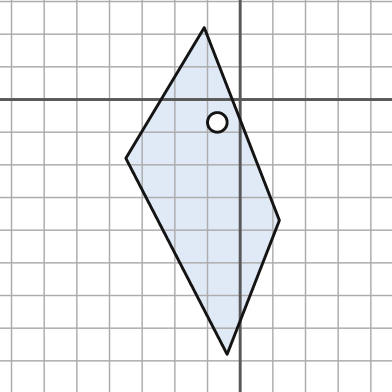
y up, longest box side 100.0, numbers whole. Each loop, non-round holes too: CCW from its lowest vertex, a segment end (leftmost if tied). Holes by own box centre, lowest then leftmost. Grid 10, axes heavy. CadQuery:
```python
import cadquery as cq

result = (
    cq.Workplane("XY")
    .moveTo(-4.0, -78.0)
    .lineTo(12.0, -37.0)
    .lineTo(-11.0, 22.0)
    .lineTo(-35.0, -18.0)
    .close()
    .moveTo(-7.0, -7.0)
    .circle(3.0)
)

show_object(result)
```